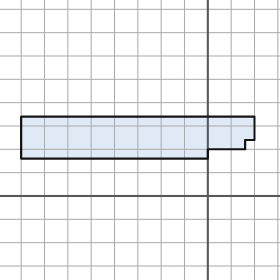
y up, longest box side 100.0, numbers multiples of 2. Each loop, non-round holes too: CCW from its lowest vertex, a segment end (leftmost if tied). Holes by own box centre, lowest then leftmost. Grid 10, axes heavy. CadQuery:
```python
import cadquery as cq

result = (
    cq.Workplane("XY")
    .moveTo(-80.0, 16.0)
    .lineTo(0.0, 16.0)
    .lineTo(0.0, 20.0)
    .lineTo(16.0, 20.0)
    .lineTo(16.0, 24.0)
    .lineTo(20.0, 24.0)
    .lineTo(20.0, 34.0)
    .lineTo(-80.0, 34.0)
    .close()
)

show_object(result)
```